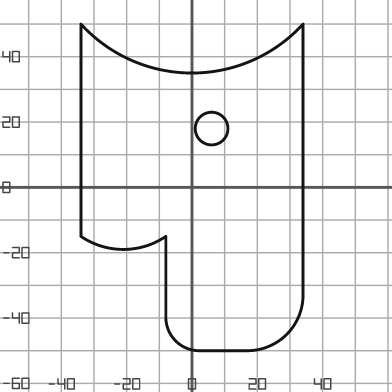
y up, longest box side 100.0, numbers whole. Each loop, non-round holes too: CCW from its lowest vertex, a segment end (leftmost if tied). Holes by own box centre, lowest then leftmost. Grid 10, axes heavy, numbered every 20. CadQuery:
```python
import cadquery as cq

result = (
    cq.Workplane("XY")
    .moveTo(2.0, -50.0)
    .lineTo(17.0, -50.0)
    .threePointArc((29.0, -45.0), (34.0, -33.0))
    .lineTo(34.0, 50.0)
    .threePointArc((0.0, 35.0), (-34.0, 50.0))
    .lineTo(-34.0, -15.0)
    .threePointArc((-21.0, -19.0), (-8.0, -15.0))
    .lineTo(-8.0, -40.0)
    .threePointArc((-5.0, -47.0), (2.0, -50.0))
    .close()
    .moveTo(6.0, 18.0)
    .circle(5.0)
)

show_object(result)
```